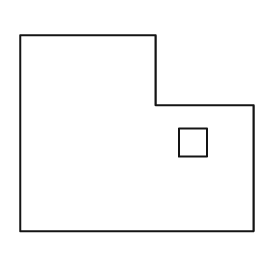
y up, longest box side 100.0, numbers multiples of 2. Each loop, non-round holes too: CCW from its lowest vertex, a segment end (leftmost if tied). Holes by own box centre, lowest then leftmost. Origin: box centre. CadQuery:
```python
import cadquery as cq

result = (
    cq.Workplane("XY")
    .moveTo(-50.0, -42.0)
    .lineTo(50.0, -42.0)
    .lineTo(50.0, 12.0)
    .lineTo(8.0, 12.0)
    .lineTo(8.0, 42.0)
    .lineTo(-50.0, 42.0)
    .close()
    .moveTo(18.0, -10.0)
    .lineTo(30.0, -10.0)
    .lineTo(30.0, 2.0)
    .lineTo(18.0, 2.0)
    .close()
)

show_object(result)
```